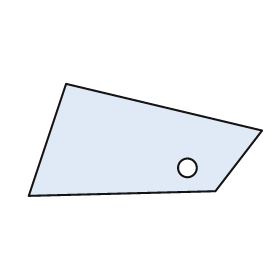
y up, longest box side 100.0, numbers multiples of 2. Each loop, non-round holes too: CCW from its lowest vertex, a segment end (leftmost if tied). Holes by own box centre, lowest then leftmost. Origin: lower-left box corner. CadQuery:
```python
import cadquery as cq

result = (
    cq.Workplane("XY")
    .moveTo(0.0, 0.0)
    .lineTo(80.0, 2.0)
    .lineTo(100.0, 28.0)
    .lineTo(16.0, 48.0)
    .close()
    .moveTo(68.0, 12.0)
    .circle(4.0)
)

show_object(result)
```